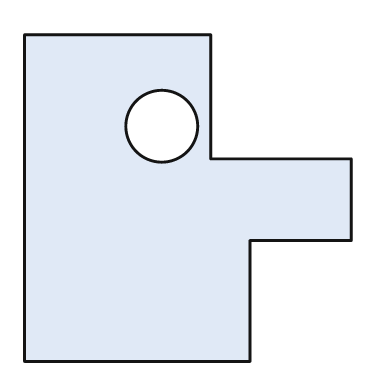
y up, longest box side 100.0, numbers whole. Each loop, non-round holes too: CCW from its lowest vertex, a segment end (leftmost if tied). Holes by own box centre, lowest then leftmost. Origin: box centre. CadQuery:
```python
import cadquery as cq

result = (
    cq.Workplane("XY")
    .moveTo(-50.0, -50.0)
    .lineTo(19.0, -50.0)
    .lineTo(19.0, -13.0)
    .lineTo(50.0, -13.0)
    .lineTo(50.0, 12.0)
    .lineTo(7.0, 12.0)
    .lineTo(7.0, 50.0)
    .lineTo(-50.0, 50.0)
    .close()
    .moveTo(-8.0, 22.0)
    .circle(11.0)
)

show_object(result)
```